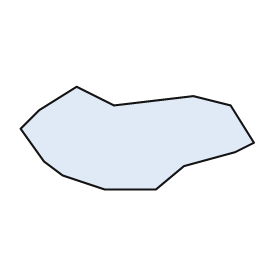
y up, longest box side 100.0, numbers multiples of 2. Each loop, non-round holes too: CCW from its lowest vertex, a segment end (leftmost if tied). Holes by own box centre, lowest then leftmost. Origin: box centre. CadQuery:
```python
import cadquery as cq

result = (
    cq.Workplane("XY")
    .moveTo(-14.0, -22.0)
    .lineTo(8.0, -22.0)
    .lineTo(20.0, -12.0)
    .lineTo(42.0, -6.0)
    .lineTo(50.0, -2.0)
    .lineTo(40.0, 14.0)
    .lineTo(24.0, 18.0)
    .lineTo(-10.0, 14.0)
    .lineTo(-26.0, 22.0)
    .lineTo(-42.0, 12.0)
    .lineTo(-50.0, 4.0)
    .lineTo(-40.0, -10.0)
    .lineTo(-32.0, -16.0)
    .close()
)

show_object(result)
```